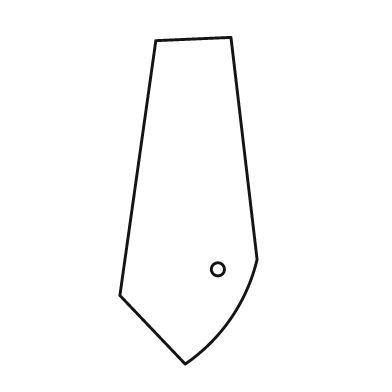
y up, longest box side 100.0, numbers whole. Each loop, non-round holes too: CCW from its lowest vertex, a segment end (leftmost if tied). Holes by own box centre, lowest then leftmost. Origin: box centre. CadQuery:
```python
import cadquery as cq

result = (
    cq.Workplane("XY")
    .moveTo(-1.0, -50.0)
    .threePointArc((13.0, -36.0), (21.0, -18.0))
    .lineTo(13.0, 50.0)
    .lineTo(-10.0, 49.0)
    .lineTo(-21.0, -29.0)
    .close()
    .moveTo(9.0, -21.0)
    .circle(2.0)
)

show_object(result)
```